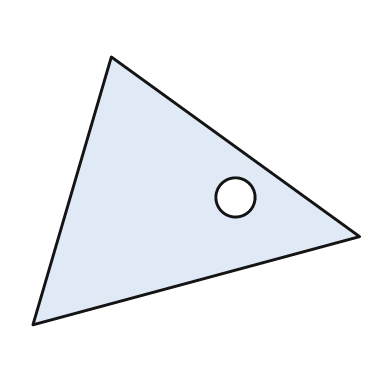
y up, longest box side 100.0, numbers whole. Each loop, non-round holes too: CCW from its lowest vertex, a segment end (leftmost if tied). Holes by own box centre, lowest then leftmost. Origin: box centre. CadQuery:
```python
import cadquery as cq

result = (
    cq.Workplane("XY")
    .moveTo(-50.0, -41.0)
    .lineTo(50.0, -14.0)
    .lineTo(-26.0, 41.0)
    .close()
    .moveTo(12.0, -2.0)
    .circle(6.0)
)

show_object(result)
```